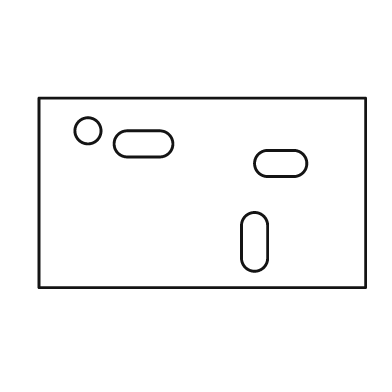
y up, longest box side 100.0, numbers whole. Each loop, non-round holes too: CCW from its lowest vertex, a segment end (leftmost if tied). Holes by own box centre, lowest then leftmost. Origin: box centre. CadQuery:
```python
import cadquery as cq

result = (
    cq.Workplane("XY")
    .moveTo(-50.0, -29.0)
    .lineTo(50.0, -29.0)
    .lineTo(50.0, 29.0)
    .lineTo(-50.0, 29.0)
    .close()
    .moveTo(12.0, -20.0)
    .threePointArc((16.0, -24.0), (20.0, -20.0))
    .lineTo(20.0, -10.0)
    .threePointArc((16.0, -6.0), (12.0, -10.0))
    .close()
    .moveTo(20.0, 5.0)
    .lineTo(28.0, 5.0)
    .threePointArc((32.0, 9.0), (28.0, 13.0))
    .lineTo(20.0, 13.0)
    .threePointArc((16.0, 9.0), (20.0, 5.0))
    .close()
    .moveTo(-23.0, 11.0)
    .lineTo(-13.0, 11.0)
    .threePointArc((-9.0, 15.0), (-13.0, 19.0))
    .lineTo(-23.0, 19.0)
    .threePointArc((-27.0, 15.0), (-23.0, 11.0))
    .close()
    .moveTo(-35.0, 19.0)
    .circle(4.0)
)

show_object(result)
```